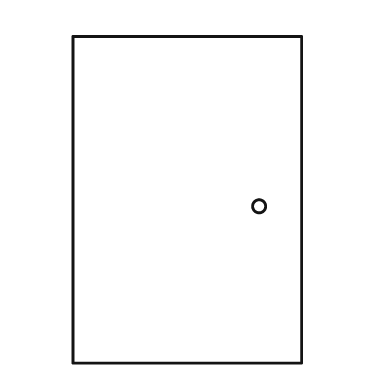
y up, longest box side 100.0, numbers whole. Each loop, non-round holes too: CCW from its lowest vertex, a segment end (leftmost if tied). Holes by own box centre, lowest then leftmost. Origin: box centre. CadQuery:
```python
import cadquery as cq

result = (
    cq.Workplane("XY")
    .moveTo(-35.0, -50.0)
    .lineTo(35.0, -50.0)
    .lineTo(35.0, 50.0)
    .lineTo(-35.0, 50.0)
    .close()
    .moveTo(22.0, -2.0)
    .circle(2.0)
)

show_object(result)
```